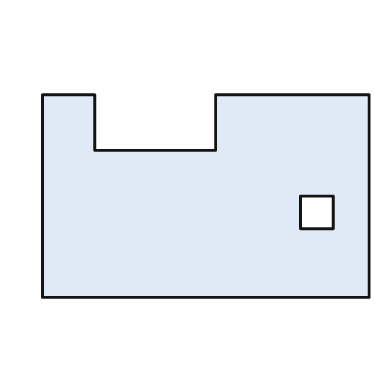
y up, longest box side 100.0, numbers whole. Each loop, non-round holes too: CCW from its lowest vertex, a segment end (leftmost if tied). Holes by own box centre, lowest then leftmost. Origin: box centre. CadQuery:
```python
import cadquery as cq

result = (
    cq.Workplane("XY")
    .moveTo(-50.0, -31.0)
    .lineTo(50.0, -31.0)
    .lineTo(50.0, 31.0)
    .lineTo(3.0, 31.0)
    .lineTo(3.0, 14.0)
    .lineTo(-34.0, 14.0)
    .lineTo(-34.0, 31.0)
    .lineTo(-50.0, 31.0)
    .close()
    .moveTo(29.0, -10.0)
    .lineTo(39.0, -10.0)
    .lineTo(39.0, 0.0)
    .lineTo(29.0, 0.0)
    .close()
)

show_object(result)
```